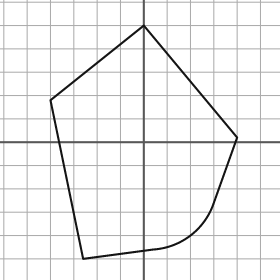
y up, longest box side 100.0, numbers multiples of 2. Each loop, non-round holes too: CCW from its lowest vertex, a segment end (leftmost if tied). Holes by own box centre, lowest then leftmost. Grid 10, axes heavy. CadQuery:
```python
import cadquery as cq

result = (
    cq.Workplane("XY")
    .moveTo(-26.0, -50.0)
    .lineTo(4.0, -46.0)
    .threePointArc((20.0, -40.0), (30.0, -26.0))
    .lineTo(40.0, 2.0)
    .lineTo(0.0, 50.0)
    .lineTo(-40.0, 18.0)
    .close()
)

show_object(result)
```